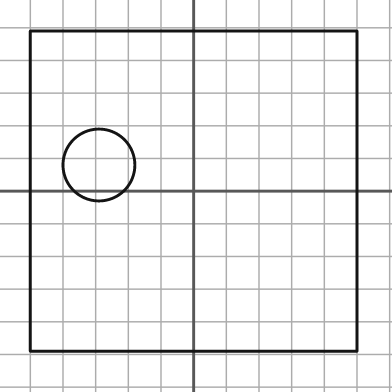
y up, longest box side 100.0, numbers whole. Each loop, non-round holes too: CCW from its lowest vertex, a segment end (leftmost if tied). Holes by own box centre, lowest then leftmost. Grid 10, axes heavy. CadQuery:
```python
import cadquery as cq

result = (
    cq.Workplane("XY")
    .moveTo(-50.0, -49.0)
    .lineTo(50.0, -49.0)
    .lineTo(50.0, 49.0)
    .lineTo(-50.0, 49.0)
    .close()
    .moveTo(-29.0, 8.0)
    .circle(11.0)
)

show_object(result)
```